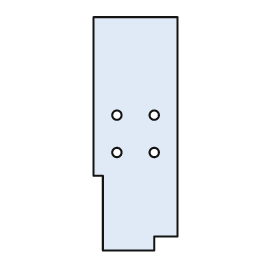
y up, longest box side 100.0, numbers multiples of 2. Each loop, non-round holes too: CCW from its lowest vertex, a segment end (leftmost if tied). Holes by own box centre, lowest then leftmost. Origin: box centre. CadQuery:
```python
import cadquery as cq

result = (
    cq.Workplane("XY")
    .moveTo(-14.0, -50.0)
    .lineTo(8.0, -50.0)
    .lineTo(8.0, -44.0)
    .lineTo(18.0, -44.0)
    .lineTo(18.0, 50.0)
    .lineTo(-18.0, 50.0)
    .lineTo(-18.0, -18.0)
    .lineTo(-14.0, -18.0)
    .close()
    .moveTo(-8.0, -8.0)
    .circle(2.0)
    .moveTo(8.0, -8.0)
    .circle(2.0)
    .moveTo(-8.0, 8.0)
    .circle(2.0)
    .moveTo(8.0, 8.0)
    .circle(2.0)
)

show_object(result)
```